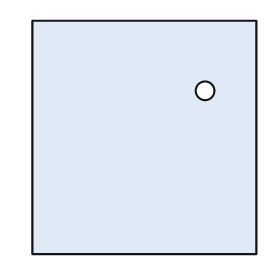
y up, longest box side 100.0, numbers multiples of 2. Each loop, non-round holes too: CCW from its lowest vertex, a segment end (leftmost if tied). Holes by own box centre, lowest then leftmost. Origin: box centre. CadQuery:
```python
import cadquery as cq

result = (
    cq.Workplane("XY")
    .moveTo(-48.0, -50.0)
    .lineTo(48.0, -50.0)
    .lineTo(48.0, 50.0)
    .lineTo(-48.0, 50.0)
    .close()
    .moveTo(26.0, 20.0)
    .circle(4.0)
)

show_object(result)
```